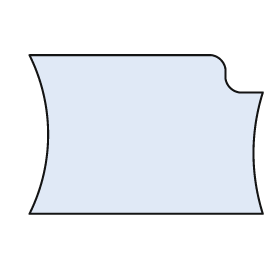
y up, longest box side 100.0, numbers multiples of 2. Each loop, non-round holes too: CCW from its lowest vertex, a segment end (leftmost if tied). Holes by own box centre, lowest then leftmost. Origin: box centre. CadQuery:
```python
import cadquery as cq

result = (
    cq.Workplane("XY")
    .moveTo(-50.0, -34.0)
    .lineTo(50.0, -34.0)
    .threePointArc((46.0, -8.0), (50.0, 18.0))
    .lineTo(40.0, 18.0)
    .threePointArc((36.0, 20.0), (34.0, 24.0))
    .lineTo(34.0, 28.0)
    .threePointArc((32.0, 32.0), (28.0, 34.0))
    .lineTo(-50.0, 34.0)
    .threePointArc((-42.0, 0.0), (-50.0, -34.0))
    .close()
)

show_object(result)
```